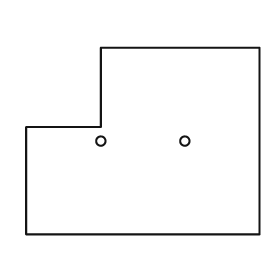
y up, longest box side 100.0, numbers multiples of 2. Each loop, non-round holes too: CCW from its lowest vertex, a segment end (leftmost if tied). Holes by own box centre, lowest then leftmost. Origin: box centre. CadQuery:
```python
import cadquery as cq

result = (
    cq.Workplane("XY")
    .moveTo(-50.0, -40.0)
    .lineTo(50.0, -40.0)
    .lineTo(50.0, 40.0)
    .lineTo(-18.0, 40.0)
    .lineTo(-18.0, 6.0)
    .lineTo(-50.0, 6.0)
    .close()
    .moveTo(-18.0, 0.0)
    .circle(2.0)
    .moveTo(18.0, 0.0)
    .circle(2.0)
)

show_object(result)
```